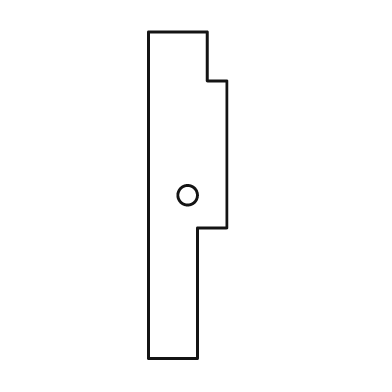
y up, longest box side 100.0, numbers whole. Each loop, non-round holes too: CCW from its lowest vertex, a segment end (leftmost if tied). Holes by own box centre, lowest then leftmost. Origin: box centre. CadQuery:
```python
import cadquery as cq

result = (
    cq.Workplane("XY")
    .moveTo(-12.0, -50.0)
    .lineTo(3.0, -50.0)
    .lineTo(3.0, -10.0)
    .lineTo(12.0, -10.0)
    .lineTo(12.0, 35.0)
    .lineTo(6.0, 35.0)
    .lineTo(6.0, 50.0)
    .lineTo(-12.0, 50.0)
    .close()
    .moveTo(0.0, 0.0)
    .circle(3.0)
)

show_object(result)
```